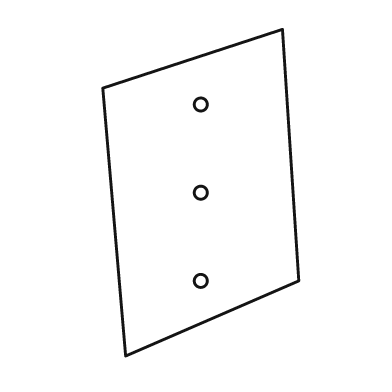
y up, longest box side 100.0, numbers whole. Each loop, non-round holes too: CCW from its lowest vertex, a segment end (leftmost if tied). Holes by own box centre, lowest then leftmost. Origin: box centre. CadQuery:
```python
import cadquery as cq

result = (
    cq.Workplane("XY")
    .moveTo(-23.0, -50.0)
    .lineTo(30.0, -27.0)
    .lineTo(25.0, 50.0)
    .lineTo(-30.0, 32.0)
    .close()
    .moveTo(0.0, -27.0)
    .circle(2.0)
    .moveTo(0.0, 0.0)
    .circle(2.0)
    .moveTo(0.0, 27.0)
    .circle(2.0)
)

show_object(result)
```